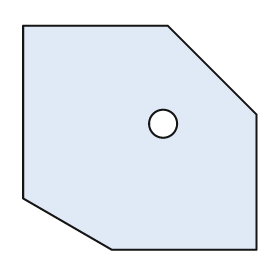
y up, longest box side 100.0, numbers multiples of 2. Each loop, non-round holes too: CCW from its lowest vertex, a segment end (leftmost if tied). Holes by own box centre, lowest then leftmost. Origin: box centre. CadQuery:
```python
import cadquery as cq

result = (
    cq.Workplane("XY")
    .moveTo(-12.0, -48.0)
    .lineTo(50.0, -48.0)
    .lineTo(50.0, 10.0)
    .lineTo(12.0, 48.0)
    .lineTo(-50.0, 48.0)
    .lineTo(-50.0, -26.0)
    .close()
    .moveTo(10.0, 6.0)
    .circle(6.0)
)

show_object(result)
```